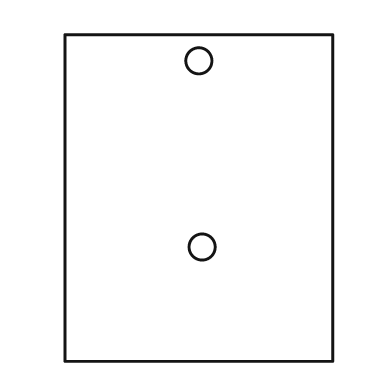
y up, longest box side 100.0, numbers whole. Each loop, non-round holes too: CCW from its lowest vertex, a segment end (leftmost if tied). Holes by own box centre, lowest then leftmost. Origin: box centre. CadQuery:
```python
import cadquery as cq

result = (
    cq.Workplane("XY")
    .moveTo(-41.0, -50.0)
    .lineTo(41.0, -50.0)
    .lineTo(41.0, 50.0)
    .lineTo(-41.0, 50.0)
    .close()
    .moveTo(1.0, -15.0)
    .circle(4.0)
    .moveTo(0.0, 42.0)
    .circle(4.0)
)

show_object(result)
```